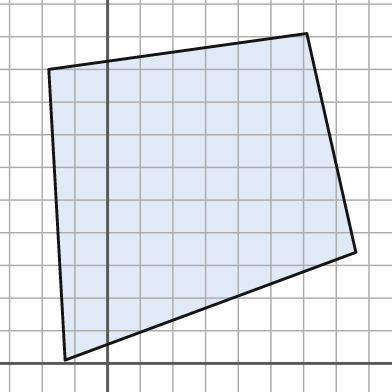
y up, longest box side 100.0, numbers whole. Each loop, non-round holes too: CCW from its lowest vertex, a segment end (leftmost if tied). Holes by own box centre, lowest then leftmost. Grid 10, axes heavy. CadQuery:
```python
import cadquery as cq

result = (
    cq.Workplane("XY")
    .moveTo(-13.0, 1.0)
    .lineTo(76.0, 34.0)
    .lineTo(61.0, 101.0)
    .lineTo(-18.0, 90.0)
    .close()
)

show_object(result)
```